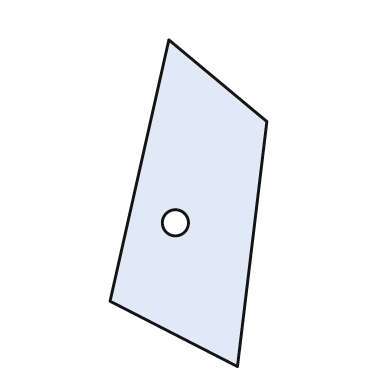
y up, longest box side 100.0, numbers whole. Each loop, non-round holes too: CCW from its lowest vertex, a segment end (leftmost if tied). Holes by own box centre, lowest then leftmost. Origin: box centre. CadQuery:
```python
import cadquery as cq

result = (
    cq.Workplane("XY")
    .moveTo(15.0, -50.0)
    .lineTo(24.0, 25.0)
    .lineTo(-6.0, 50.0)
    .lineTo(-24.0, -30.0)
    .close()
    .moveTo(-4.0, -6.0)
    .circle(4.0)
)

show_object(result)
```